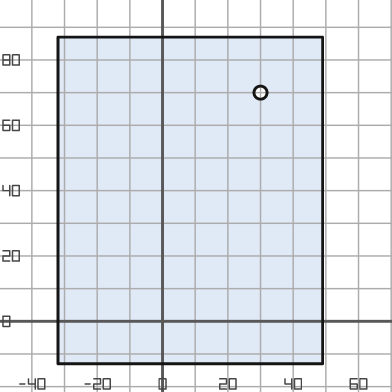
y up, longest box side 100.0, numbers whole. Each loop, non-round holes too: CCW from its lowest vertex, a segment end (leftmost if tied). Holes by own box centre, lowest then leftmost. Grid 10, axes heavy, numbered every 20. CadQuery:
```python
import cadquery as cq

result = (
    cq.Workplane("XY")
    .moveTo(-32.0, -13.0)
    .lineTo(49.0, -13.0)
    .lineTo(49.0, 87.0)
    .lineTo(-32.0, 87.0)
    .close()
    .moveTo(30.0, 70.0)
    .circle(2.0)
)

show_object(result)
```